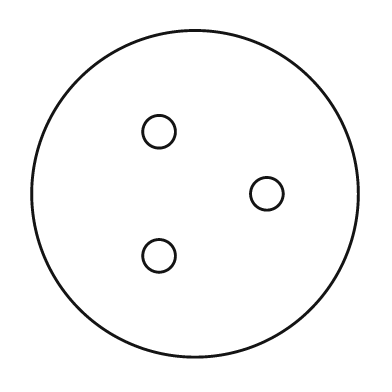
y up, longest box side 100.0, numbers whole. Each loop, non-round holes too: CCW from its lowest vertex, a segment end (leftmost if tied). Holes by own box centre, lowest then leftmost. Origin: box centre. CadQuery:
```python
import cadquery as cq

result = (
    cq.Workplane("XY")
    .moveTo(0.0, 0.0)
    .circle(50.0)
    .moveTo(-11.0, -19.0)
    .circle(5.0)
    .moveTo(22.0, 0.0)
    .circle(5.0)
    .moveTo(-11.0, 19.0)
    .circle(5.0)
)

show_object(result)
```